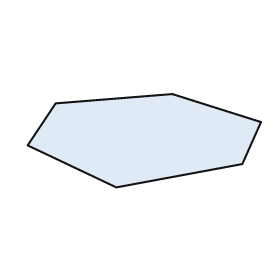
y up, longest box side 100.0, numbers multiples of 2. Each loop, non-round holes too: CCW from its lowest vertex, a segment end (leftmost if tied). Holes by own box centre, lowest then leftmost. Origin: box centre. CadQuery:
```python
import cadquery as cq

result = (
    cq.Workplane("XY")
    .moveTo(-12.0, -20.0)
    .lineTo(42.0, -10.0)
    .lineTo(50.0, 8.0)
    .lineTo(12.0, 20.0)
    .lineTo(-38.0, 16.0)
    .lineTo(-50.0, -2.0)
    .close()
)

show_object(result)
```